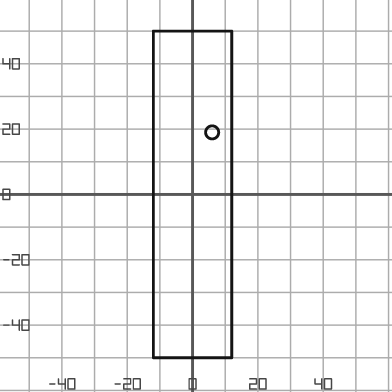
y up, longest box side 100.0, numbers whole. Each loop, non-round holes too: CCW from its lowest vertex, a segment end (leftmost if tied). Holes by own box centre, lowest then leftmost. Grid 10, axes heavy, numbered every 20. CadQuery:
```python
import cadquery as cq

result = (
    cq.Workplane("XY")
    .moveTo(-12.0, -50.0)
    .lineTo(12.0, -50.0)
    .lineTo(12.0, 50.0)
    .lineTo(-12.0, 50.0)
    .close()
    .moveTo(6.0, 19.0)
    .circle(2.0)
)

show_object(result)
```